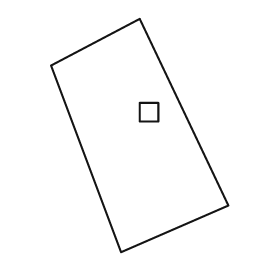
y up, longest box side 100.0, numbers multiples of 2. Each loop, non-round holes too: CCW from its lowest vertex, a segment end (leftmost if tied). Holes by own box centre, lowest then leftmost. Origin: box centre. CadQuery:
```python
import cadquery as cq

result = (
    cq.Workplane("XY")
    .moveTo(-8.0, -50.0)
    .lineTo(38.0, -30.0)
    .lineTo(0.0, 50.0)
    .lineTo(-38.0, 30.0)
    .close()
    .moveTo(0.0, 6.0)
    .lineTo(8.0, 6.0)
    .lineTo(8.0, 14.0)
    .lineTo(0.0, 14.0)
    .close()
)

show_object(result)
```